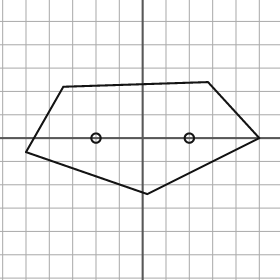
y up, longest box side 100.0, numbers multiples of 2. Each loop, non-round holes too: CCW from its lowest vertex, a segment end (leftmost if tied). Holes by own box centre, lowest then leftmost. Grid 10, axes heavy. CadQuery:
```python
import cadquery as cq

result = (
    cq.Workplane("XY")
    .moveTo(2.0, -24.0)
    .lineTo(50.0, 0.0)
    .lineTo(28.0, 24.0)
    .lineTo(-34.0, 22.0)
    .lineTo(-50.0, -6.0)
    .close()
    .moveTo(-20.0, 0.0)
    .circle(2.0)
    .moveTo(20.0, 0.0)
    .circle(2.0)
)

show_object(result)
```